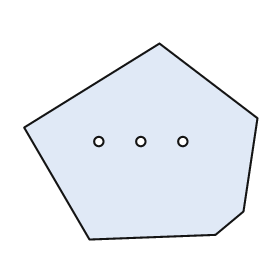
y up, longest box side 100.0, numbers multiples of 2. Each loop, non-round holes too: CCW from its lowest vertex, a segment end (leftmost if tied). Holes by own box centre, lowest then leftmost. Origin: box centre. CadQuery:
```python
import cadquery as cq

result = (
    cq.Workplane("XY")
    .moveTo(-22.0, -42.0)
    .lineTo(32.0, -40.0)
    .lineTo(44.0, -30.0)
    .lineTo(50.0, 10.0)
    .lineTo(8.0, 42.0)
    .lineTo(-50.0, 6.0)
    .close()
    .moveTo(-18.0, 0.0)
    .circle(2.0)
    .moveTo(0.0, 0.0)
    .circle(2.0)
    .moveTo(18.0, 0.0)
    .circle(2.0)
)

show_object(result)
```